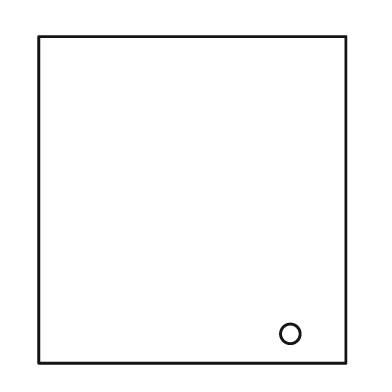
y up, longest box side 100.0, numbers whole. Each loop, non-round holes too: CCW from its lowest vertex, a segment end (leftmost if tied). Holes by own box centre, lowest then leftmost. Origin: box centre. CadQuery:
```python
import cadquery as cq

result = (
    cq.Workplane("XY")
    .moveTo(-47.0, -50.0)
    .lineTo(47.0, -50.0)
    .lineTo(47.0, 50.0)
    .lineTo(-47.0, 50.0)
    .close()
    .moveTo(30.0, -41.0)
    .circle(3.0)
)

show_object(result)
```